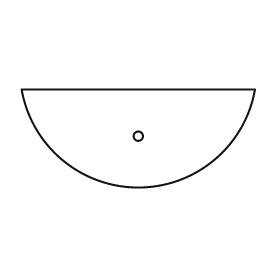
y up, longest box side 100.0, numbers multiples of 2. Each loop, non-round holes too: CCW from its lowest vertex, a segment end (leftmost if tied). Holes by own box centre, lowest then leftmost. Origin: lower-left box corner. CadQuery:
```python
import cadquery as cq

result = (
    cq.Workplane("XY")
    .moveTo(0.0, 42.0)
    .threePointArc((50.0, 0.0), (100.0, 42.0))
    .close()
    .moveTo(50.0, 22.0)
    .circle(2.0)
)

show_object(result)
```